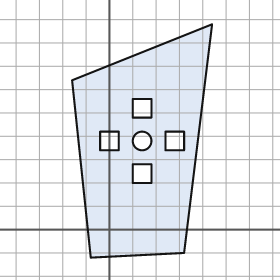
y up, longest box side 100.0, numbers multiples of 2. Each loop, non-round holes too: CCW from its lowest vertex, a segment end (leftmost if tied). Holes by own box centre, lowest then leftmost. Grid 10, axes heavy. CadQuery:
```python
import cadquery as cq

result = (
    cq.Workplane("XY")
    .moveTo(-8.0, -12.0)
    .lineTo(32.0, -10.0)
    .lineTo(44.0, 88.0)
    .lineTo(-16.0, 64.0)
    .close()
    .moveTo(10.0, 20.0)
    .lineTo(18.0, 20.0)
    .lineTo(18.0, 28.0)
    .lineTo(10.0, 28.0)
    .close()
    .moveTo(-4.0, 34.0)
    .lineTo(4.0, 34.0)
    .lineTo(4.0, 42.0)
    .lineTo(-4.0, 42.0)
    .close()
    .moveTo(14.0, 38.0)
    .circle(4.0)
    .moveTo(24.0, 34.0)
    .lineTo(32.0, 34.0)
    .lineTo(32.0, 42.0)
    .lineTo(24.0, 42.0)
    .close()
    .moveTo(10.0, 48.0)
    .lineTo(18.0, 48.0)
    .lineTo(18.0, 56.0)
    .lineTo(10.0, 56.0)
    .close()
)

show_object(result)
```